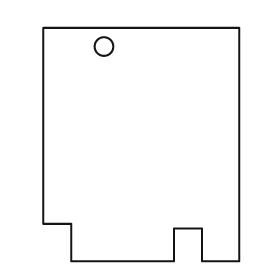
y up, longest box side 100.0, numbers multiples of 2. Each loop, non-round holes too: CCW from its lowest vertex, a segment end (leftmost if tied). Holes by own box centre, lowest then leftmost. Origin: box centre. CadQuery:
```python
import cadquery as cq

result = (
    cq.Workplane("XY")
    .moveTo(-30.0, -50.0)
    .lineTo(14.0, -50.0)
    .lineTo(14.0, -36.0)
    .lineTo(26.0, -36.0)
    .lineTo(26.0, -50.0)
    .lineTo(42.0, -50.0)
    .lineTo(42.0, 50.0)
    .lineTo(-42.0, 50.0)
    .lineTo(-42.0, -34.0)
    .lineTo(-30.0, -34.0)
    .close()
    .moveTo(-16.0, 42.0)
    .circle(4.0)
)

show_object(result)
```